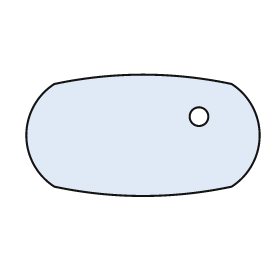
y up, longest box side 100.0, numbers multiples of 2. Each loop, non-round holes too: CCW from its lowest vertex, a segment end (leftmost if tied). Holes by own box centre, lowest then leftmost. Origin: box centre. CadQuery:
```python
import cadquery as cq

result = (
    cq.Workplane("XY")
    .moveTo(-38.0, -22.0)
    .threePointArc((0.0, -26.0), (38.0, -22.0))
    .threePointArc((50.0, 0.0), (38.0, 22.0))
    .threePointArc((0.0, 26.0), (-38.0, 22.0))
    .threePointArc((-50.0, 0.0), (-38.0, -22.0))
    .close()
    .moveTo(24.0, 8.0)
    .circle(4.0)
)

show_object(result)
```